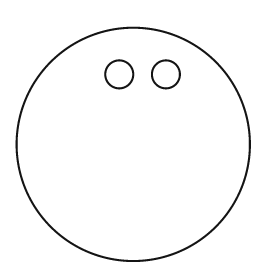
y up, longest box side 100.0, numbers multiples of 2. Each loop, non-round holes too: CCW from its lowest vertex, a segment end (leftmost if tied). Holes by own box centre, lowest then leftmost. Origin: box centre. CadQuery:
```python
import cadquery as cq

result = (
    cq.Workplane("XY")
    .moveTo(0.0, 0.0)
    .circle(50.0)
    .moveTo(-6.0, 30.0)
    .circle(6.0)
    .moveTo(14.0, 30.0)
    .circle(6.0)
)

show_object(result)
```